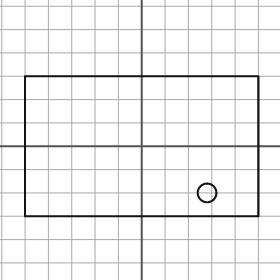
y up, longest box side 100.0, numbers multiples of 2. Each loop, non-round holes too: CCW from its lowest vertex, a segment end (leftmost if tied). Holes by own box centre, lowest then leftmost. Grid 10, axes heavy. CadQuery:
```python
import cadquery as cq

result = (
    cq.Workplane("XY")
    .moveTo(-50.0, -30.0)
    .lineTo(50.0, -30.0)
    .lineTo(50.0, 30.0)
    .lineTo(-50.0, 30.0)
    .close()
    .moveTo(28.0, -20.0)
    .circle(4.0)
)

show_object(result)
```